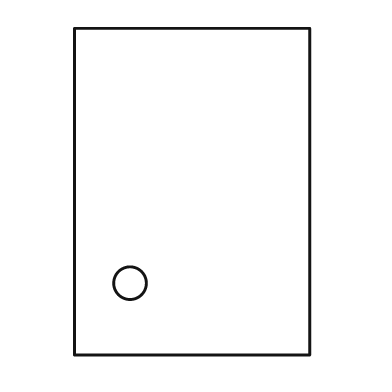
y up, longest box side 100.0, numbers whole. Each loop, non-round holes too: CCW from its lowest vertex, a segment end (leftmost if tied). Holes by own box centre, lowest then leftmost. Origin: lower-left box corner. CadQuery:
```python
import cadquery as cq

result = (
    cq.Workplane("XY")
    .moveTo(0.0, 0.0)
    .lineTo(72.0, 0.0)
    .lineTo(72.0, 100.0)
    .lineTo(0.0, 100.0)
    .close()
    .moveTo(17.0, 22.0)
    .circle(5.0)
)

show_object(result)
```